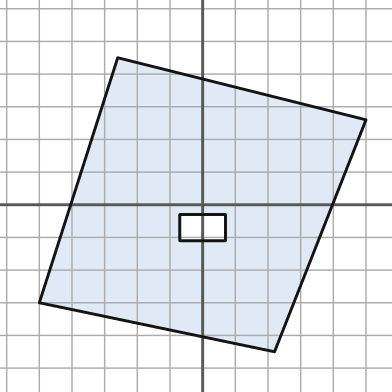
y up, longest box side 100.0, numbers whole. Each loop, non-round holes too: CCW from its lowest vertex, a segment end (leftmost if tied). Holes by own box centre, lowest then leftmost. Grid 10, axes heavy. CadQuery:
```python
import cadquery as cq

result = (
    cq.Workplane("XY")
    .moveTo(22.0, -45.0)
    .lineTo(50.0, 26.0)
    .lineTo(-26.0, 45.0)
    .lineTo(-50.0, -30.0)
    .close()
    .moveTo(-7.0, -11.0)
    .lineTo(7.0, -11.0)
    .lineTo(7.0, -3.0)
    .lineTo(-7.0, -3.0)
    .close()
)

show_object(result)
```